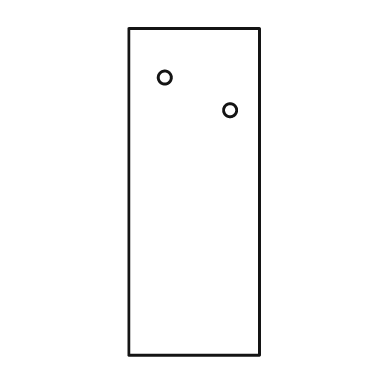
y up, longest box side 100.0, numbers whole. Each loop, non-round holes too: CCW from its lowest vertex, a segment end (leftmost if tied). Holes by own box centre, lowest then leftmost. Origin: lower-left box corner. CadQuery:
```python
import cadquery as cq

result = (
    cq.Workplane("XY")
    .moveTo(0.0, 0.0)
    .lineTo(40.0, 0.0)
    .lineTo(40.0, 100.0)
    .lineTo(0.0, 100.0)
    .close()
    .moveTo(31.0, 75.0)
    .circle(2.0)
    .moveTo(11.0, 85.0)
    .circle(2.0)
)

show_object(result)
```